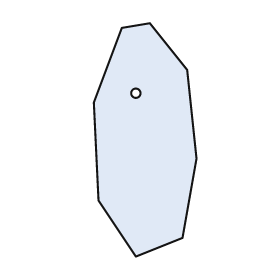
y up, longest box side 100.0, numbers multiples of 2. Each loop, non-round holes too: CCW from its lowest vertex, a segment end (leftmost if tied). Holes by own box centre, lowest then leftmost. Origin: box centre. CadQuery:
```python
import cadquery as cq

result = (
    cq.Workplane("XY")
    .moveTo(-4.0, -50.0)
    .lineTo(16.0, -42.0)
    .lineTo(22.0, -8.0)
    .lineTo(18.0, 30.0)
    .lineTo(2.0, 50.0)
    .lineTo(-10.0, 48.0)
    .lineTo(-22.0, 16.0)
    .lineTo(-20.0, -26.0)
    .close()
    .moveTo(-4.0, 20.0)
    .circle(2.0)
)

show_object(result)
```